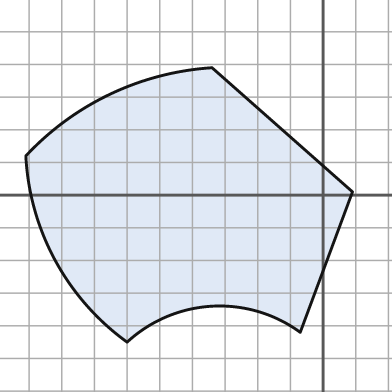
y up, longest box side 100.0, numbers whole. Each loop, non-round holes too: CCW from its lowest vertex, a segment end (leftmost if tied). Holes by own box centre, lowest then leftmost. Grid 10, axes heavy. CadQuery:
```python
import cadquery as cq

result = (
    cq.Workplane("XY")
    .moveTo(-60.0, -45.0)
    .threePointArc((-34.0, -34.0), (-7.0, -42.0))
    .lineTo(9.0, 1.0)
    .lineTo(-34.0, 39.0)
    .threePointArc((-65.0, 31.0), (-91.0, 12.0))
    .threePointArc((-82.0, -20.0), (-60.0, -45.0))
    .close()
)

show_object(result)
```